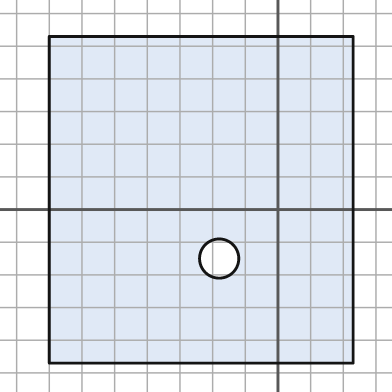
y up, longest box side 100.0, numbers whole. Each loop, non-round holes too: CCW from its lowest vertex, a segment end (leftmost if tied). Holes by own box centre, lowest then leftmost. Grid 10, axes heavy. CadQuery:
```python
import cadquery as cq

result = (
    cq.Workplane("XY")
    .moveTo(-70.0, -47.0)
    .lineTo(23.0, -47.0)
    .lineTo(23.0, 53.0)
    .lineTo(-70.0, 53.0)
    .close()
    .moveTo(-18.0, -15.0)
    .circle(6.0)
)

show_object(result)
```